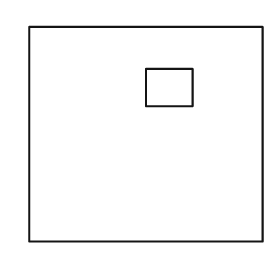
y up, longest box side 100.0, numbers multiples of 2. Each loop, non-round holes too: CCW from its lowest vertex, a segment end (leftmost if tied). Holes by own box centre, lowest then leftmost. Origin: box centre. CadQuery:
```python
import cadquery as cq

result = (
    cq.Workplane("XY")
    .moveTo(-50.0, -46.0)
    .lineTo(50.0, -46.0)
    .lineTo(50.0, 46.0)
    .lineTo(-50.0, 46.0)
    .close()
    .moveTo(0.0, 12.0)
    .lineTo(20.0, 12.0)
    .lineTo(20.0, 28.0)
    .lineTo(0.0, 28.0)
    .close()
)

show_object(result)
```